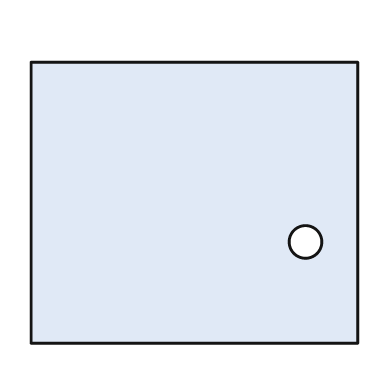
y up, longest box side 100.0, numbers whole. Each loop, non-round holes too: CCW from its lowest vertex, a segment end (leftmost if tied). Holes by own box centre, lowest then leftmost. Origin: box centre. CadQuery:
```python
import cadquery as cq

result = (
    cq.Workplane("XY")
    .moveTo(-50.0, -43.0)
    .lineTo(50.0, -43.0)
    .lineTo(50.0, 43.0)
    .lineTo(-50.0, 43.0)
    .close()
    .moveTo(34.0, -12.0)
    .circle(5.0)
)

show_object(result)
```